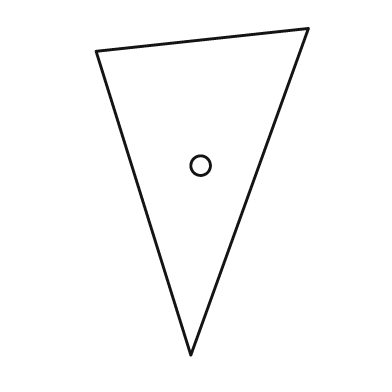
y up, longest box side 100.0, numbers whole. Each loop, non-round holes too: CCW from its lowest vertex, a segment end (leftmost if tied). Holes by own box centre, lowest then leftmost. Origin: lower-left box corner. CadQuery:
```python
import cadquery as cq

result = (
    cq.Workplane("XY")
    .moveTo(29.0, 0.0)
    .lineTo(65.0, 100.0)
    .lineTo(0.0, 93.0)
    .close()
    .moveTo(32.0, 58.0)
    .circle(3.0)
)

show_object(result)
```